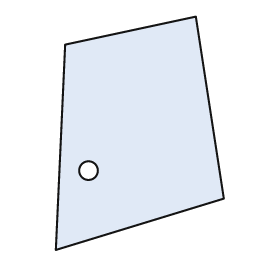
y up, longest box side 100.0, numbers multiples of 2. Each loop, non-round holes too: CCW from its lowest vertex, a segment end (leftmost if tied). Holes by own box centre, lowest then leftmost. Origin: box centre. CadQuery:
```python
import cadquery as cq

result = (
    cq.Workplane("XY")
    .moveTo(-36.0, -50.0)
    .lineTo(36.0, -28.0)
    .lineTo(24.0, 50.0)
    .lineTo(-32.0, 38.0)
    .close()
    .moveTo(-22.0, -16.0)
    .circle(4.0)
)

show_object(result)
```